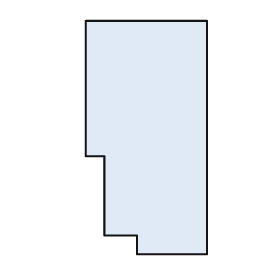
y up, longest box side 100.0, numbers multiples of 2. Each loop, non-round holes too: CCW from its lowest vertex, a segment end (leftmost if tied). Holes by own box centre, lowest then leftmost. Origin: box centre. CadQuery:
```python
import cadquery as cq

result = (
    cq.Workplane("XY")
    .moveTo(-4.0, -50.0)
    .lineTo(26.0, -50.0)
    .lineTo(26.0, 50.0)
    .lineTo(-26.0, 50.0)
    .lineTo(-26.0, -8.0)
    .lineTo(-18.0, -8.0)
    .lineTo(-18.0, -42.0)
    .lineTo(-4.0, -42.0)
    .close()
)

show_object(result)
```